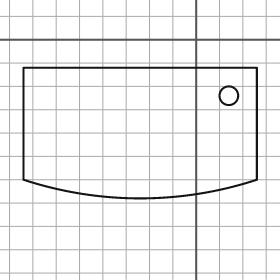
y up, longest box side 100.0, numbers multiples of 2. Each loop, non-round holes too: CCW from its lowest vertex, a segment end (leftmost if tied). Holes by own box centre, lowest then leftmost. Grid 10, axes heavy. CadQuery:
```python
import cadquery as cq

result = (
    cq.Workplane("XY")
    .moveTo(-74.0, -60.0)
    .threePointArc((-24.0, -68.0), (26.0, -60.0))
    .lineTo(26.0, -12.0)
    .lineTo(-74.0, -12.0)
    .close()
    .moveTo(14.0, -24.0)
    .circle(4.0)
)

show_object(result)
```